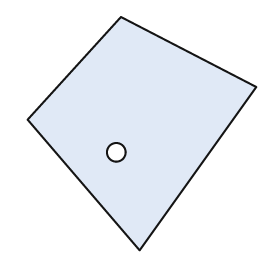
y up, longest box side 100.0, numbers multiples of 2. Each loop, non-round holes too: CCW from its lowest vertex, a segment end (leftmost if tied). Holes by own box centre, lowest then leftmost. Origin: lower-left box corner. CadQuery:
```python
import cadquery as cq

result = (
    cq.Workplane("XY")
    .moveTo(48.0, 0.0)
    .lineTo(98.0, 70.0)
    .lineTo(40.0, 100.0)
    .lineTo(0.0, 56.0)
    .close()
    .moveTo(38.0, 42.0)
    .circle(4.0)
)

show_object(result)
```